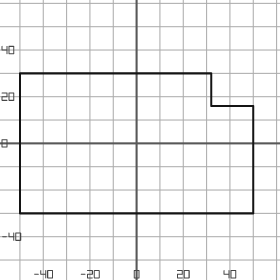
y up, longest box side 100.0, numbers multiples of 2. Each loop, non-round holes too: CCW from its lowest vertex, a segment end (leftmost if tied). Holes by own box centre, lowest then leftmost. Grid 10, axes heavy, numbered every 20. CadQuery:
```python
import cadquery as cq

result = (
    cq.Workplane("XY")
    .moveTo(-50.0, -30.0)
    .lineTo(50.0, -30.0)
    .lineTo(50.0, 16.0)
    .lineTo(32.0, 16.0)
    .lineTo(32.0, 30.0)
    .lineTo(-50.0, 30.0)
    .close()
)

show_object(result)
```